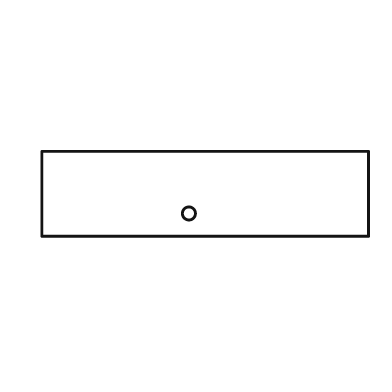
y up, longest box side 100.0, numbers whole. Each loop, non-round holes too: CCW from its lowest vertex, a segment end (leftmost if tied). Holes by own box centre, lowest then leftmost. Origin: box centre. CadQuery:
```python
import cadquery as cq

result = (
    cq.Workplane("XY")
    .moveTo(-50.0, -13.0)
    .lineTo(50.0, -13.0)
    .lineTo(50.0, 13.0)
    .lineTo(-50.0, 13.0)
    .close()
    .moveTo(-5.0, -6.0)
    .circle(2.0)
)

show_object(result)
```